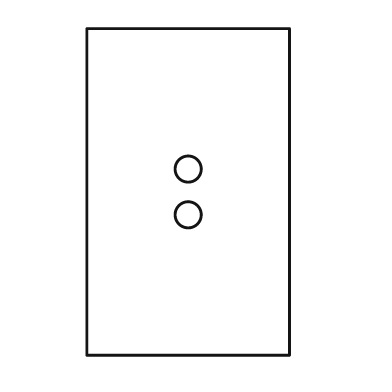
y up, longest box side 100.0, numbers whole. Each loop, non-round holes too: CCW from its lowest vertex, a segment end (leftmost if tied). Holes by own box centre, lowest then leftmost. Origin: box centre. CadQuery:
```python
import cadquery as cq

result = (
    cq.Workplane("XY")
    .moveTo(-31.0, -50.0)
    .lineTo(31.0, -50.0)
    .lineTo(31.0, 50.0)
    .lineTo(-31.0, 50.0)
    .close()
    .moveTo(0.0, -7.0)
    .circle(4.0)
    .moveTo(0.0, 7.0)
    .circle(4.0)
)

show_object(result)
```